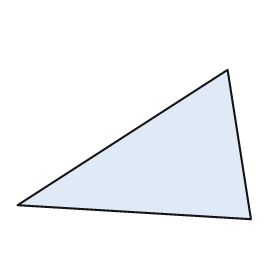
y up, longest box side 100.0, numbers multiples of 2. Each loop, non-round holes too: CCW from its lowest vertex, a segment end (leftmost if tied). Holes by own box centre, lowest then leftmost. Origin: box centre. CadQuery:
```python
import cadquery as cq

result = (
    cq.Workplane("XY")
    .moveTo(50.0, -32.0)
    .lineTo(40.0, 32.0)
    .lineTo(-50.0, -26.0)
    .close()
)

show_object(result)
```